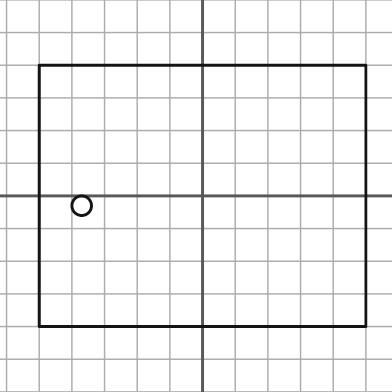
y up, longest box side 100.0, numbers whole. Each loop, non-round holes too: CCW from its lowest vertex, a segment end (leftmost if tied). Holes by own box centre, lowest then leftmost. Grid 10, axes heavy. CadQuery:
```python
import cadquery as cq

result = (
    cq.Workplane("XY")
    .moveTo(-50.0, -40.0)
    .lineTo(50.0, -40.0)
    .lineTo(50.0, 40.0)
    .lineTo(-50.0, 40.0)
    .close()
    .moveTo(-37.0, -3.0)
    .circle(3.0)
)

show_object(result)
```